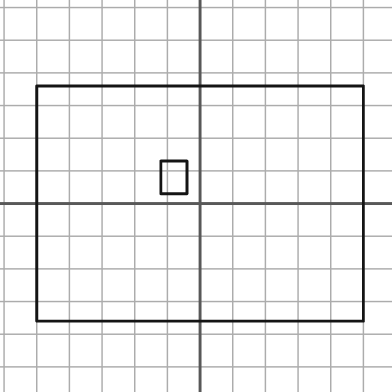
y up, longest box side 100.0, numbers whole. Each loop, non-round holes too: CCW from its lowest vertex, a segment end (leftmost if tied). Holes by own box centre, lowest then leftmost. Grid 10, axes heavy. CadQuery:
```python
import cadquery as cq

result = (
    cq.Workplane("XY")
    .moveTo(-50.0, -36.0)
    .lineTo(50.0, -36.0)
    .lineTo(50.0, 36.0)
    .lineTo(-50.0, 36.0)
    .close()
    .moveTo(-12.0, 3.0)
    .lineTo(-4.0, 3.0)
    .lineTo(-4.0, 13.0)
    .lineTo(-12.0, 13.0)
    .close()
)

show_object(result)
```